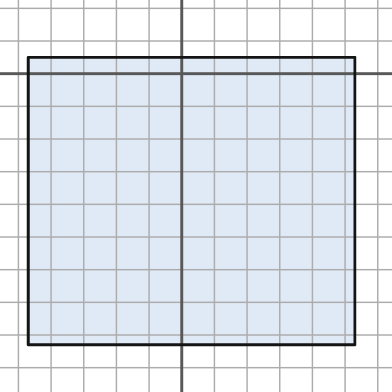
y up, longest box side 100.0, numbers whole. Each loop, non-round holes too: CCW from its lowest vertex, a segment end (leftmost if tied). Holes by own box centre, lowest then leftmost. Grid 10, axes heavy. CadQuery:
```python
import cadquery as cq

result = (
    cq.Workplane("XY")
    .moveTo(-47.0, -83.0)
    .lineTo(53.0, -83.0)
    .lineTo(53.0, 5.0)
    .lineTo(-47.0, 5.0)
    .close()
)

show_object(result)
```